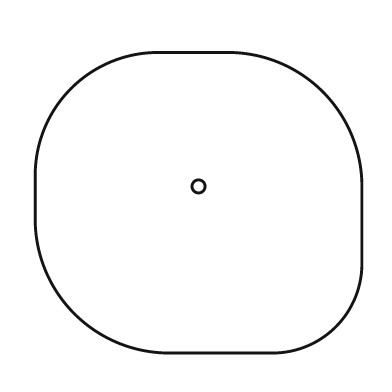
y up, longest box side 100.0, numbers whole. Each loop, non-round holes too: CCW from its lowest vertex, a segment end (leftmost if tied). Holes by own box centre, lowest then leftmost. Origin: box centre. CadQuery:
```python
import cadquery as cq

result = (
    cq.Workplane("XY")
    .moveTo(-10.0, -46.0)
    .lineTo(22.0, -46.0)
    .threePointArc((42.0, -38.0), (50.0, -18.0))
    .lineTo(50.0, 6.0)
    .threePointArc((38.0, 34.0), (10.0, 46.0))
    .lineTo(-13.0, 46.0)
    .threePointArc((-39.0, 35.0), (-50.0, 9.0))
    .lineTo(-50.0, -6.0)
    .threePointArc((-38.0, -34.0), (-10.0, -46.0))
    .close()
    .moveTo(0.0, 5.0)
    .circle(2.0)
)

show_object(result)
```